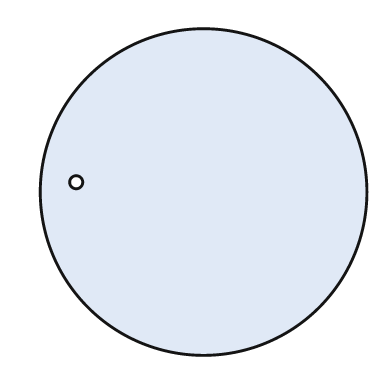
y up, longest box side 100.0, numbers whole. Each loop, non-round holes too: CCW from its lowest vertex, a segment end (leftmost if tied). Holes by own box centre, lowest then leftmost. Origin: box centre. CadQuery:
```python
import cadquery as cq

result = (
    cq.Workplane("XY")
    .moveTo(0.0, 0.0)
    .circle(50.0)
    .moveTo(-39.0, 3.0)
    .circle(2.0)
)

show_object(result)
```